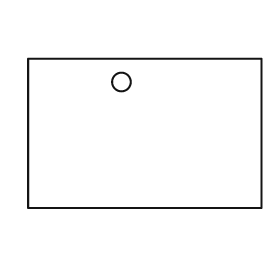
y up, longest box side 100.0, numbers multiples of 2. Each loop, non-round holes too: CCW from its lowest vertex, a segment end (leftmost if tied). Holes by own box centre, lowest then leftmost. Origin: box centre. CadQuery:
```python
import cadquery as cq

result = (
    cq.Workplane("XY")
    .moveTo(-50.0, -32.0)
    .lineTo(50.0, -32.0)
    .lineTo(50.0, 32.0)
    .lineTo(-50.0, 32.0)
    .close()
    .moveTo(-10.0, 22.0)
    .circle(4.0)
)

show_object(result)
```